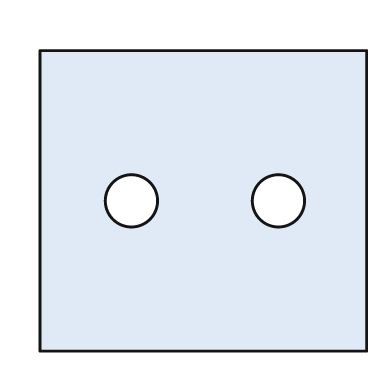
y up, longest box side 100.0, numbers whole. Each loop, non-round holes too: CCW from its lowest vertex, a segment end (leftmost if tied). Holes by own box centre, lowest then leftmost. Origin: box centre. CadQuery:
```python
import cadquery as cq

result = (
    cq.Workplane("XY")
    .moveTo(-50.0, -46.0)
    .lineTo(50.0, -46.0)
    .lineTo(50.0, 46.0)
    .lineTo(-50.0, 46.0)
    .close()
    .moveTo(-22.0, 0.0)
    .circle(8.0)
    .moveTo(23.0, 0.0)
    .circle(8.0)
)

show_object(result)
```